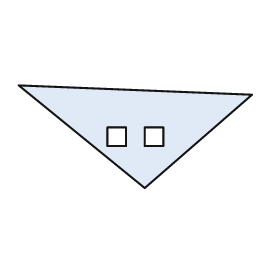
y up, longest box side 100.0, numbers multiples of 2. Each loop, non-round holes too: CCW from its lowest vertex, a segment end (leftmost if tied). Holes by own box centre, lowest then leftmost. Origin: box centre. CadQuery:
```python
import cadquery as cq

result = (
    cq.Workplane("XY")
    .moveTo(4.0, -22.0)
    .lineTo(50.0, 18.0)
    .lineTo(-50.0, 22.0)
    .close()
    .moveTo(-12.0, -4.0)
    .lineTo(-4.0, -4.0)
    .lineTo(-4.0, 4.0)
    .lineTo(-12.0, 4.0)
    .close()
    .moveTo(4.0, -4.0)
    .lineTo(12.0, -4.0)
    .lineTo(12.0, 4.0)
    .lineTo(4.0, 4.0)
    .close()
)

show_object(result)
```